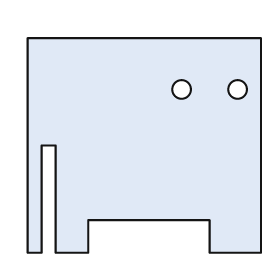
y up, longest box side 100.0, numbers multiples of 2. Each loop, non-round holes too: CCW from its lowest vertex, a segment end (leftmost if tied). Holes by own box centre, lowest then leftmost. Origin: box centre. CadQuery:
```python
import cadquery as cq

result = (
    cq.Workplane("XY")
    .moveTo(-50.0, -46.0)
    .lineTo(-44.0, -46.0)
    .lineTo(-44.0, 0.0)
    .lineTo(-38.0, 0.0)
    .lineTo(-38.0, -46.0)
    .lineTo(-24.0, -46.0)
    .lineTo(-24.0, -32.0)
    .lineTo(28.0, -32.0)
    .lineTo(28.0, -46.0)
    .lineTo(50.0, -46.0)
    .lineTo(50.0, 46.0)
    .lineTo(-50.0, 46.0)
    .close()
    .moveTo(16.0, 24.0)
    .circle(4.0)
    .moveTo(40.0, 24.0)
    .circle(4.0)
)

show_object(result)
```